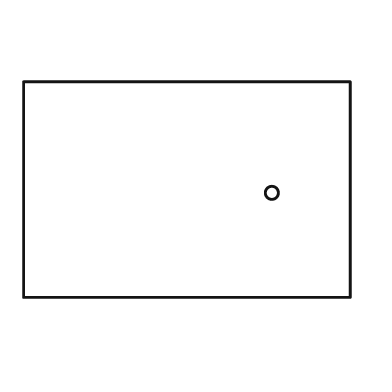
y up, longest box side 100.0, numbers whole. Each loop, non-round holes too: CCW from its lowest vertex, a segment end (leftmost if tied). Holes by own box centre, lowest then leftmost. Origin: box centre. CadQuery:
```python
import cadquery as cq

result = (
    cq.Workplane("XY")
    .moveTo(-50.0, -33.0)
    .lineTo(50.0, -33.0)
    .lineTo(50.0, 33.0)
    .lineTo(-50.0, 33.0)
    .close()
    .moveTo(26.0, -1.0)
    .circle(2.0)
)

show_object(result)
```